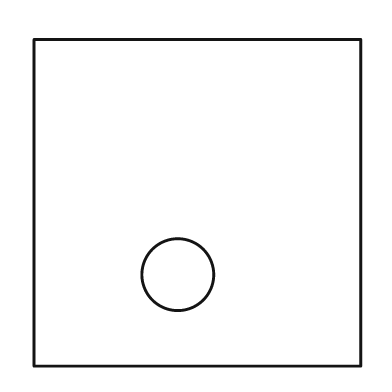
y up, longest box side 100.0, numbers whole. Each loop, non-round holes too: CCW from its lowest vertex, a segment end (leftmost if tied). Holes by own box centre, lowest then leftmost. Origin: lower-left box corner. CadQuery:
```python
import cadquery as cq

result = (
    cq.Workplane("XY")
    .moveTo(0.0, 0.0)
    .lineTo(100.0, 0.0)
    .lineTo(100.0, 100.0)
    .lineTo(0.0, 100.0)
    .close()
    .moveTo(44.0, 28.0)
    .circle(11.0)
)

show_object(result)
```